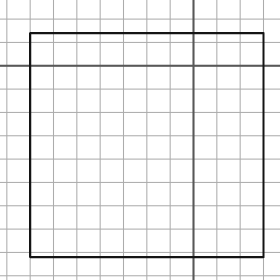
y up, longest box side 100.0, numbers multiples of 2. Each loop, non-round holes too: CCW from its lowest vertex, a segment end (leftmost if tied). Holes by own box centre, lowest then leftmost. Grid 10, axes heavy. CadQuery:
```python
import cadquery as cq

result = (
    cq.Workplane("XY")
    .moveTo(-70.0, -82.0)
    .lineTo(30.0, -82.0)
    .lineTo(30.0, 14.0)
    .lineTo(-70.0, 14.0)
    .close()
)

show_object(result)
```